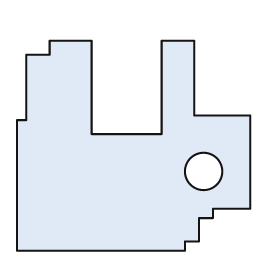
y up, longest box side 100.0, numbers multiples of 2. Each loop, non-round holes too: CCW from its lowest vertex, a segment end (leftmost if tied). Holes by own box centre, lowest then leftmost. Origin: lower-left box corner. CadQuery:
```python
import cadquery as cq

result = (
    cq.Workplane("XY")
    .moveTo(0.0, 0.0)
    .lineTo(72.0, 0.0)
    .lineTo(72.0, 4.0)
    .lineTo(78.0, 4.0)
    .lineTo(78.0, 14.0)
    .lineTo(84.0, 14.0)
    .lineTo(84.0, 18.0)
    .lineTo(100.0, 18.0)
    .lineTo(100.0, 58.0)
    .lineTo(76.0, 58.0)
    .lineTo(76.0, 90.0)
    .lineTo(62.0, 90.0)
    .lineTo(62.0, 50.0)
    .lineTo(32.0, 50.0)
    .lineTo(32.0, 90.0)
    .lineTo(14.0, 90.0)
    .lineTo(14.0, 84.0)
    .lineTo(4.0, 84.0)
    .lineTo(4.0, 56.0)
    .lineTo(0.0, 56.0)
    .close()
    .moveTo(80.0, 34.0)
    .circle(8.0)
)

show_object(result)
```